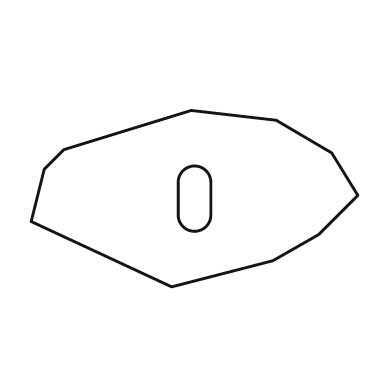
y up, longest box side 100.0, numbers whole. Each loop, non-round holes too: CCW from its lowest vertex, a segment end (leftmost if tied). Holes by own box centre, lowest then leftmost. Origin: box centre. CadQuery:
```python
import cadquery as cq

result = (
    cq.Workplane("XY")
    .moveTo(-7.0, -27.0)
    .lineTo(24.0, -19.0)
    .lineTo(38.0, -11.0)
    .lineTo(50.0, 1.0)
    .lineTo(42.0, 14.0)
    .lineTo(25.0, 24.0)
    .lineTo(-1.0, 27.0)
    .lineTo(-40.0, 15.0)
    .lineTo(-46.0, 9.0)
    .lineTo(-50.0, -7.0)
    .close()
    .moveTo(-5.0, -5.0)
    .threePointArc((0.0, -10.0), (5.0, -5.0))
    .lineTo(5.0, 5.0)
    .threePointArc((0.0, 10.0), (-5.0, 5.0))
    .close()
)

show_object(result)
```